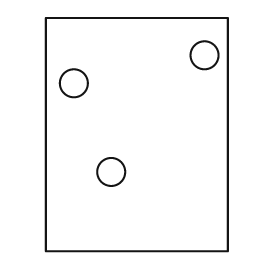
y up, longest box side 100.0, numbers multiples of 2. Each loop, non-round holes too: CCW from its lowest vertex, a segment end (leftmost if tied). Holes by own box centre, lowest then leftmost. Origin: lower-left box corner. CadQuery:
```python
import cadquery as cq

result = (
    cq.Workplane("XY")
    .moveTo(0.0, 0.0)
    .lineTo(78.0, 0.0)
    .lineTo(78.0, 100.0)
    .lineTo(0.0, 100.0)
    .close()
    .moveTo(28.0, 34.0)
    .circle(6.0)
    .moveTo(12.0, 72.0)
    .circle(6.0)
    .moveTo(68.0, 84.0)
    .circle(6.0)
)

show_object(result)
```